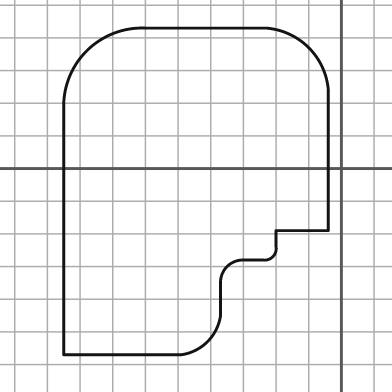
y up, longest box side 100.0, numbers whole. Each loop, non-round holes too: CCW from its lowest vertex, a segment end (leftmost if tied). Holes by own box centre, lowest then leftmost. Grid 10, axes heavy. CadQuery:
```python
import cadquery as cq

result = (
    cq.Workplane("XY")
    .moveTo(-85.0, -57.0)
    .lineTo(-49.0, -57.0)
    .threePointArc((-41.0, -53.0), (-37.0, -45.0))
    .lineTo(-37.0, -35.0)
    .threePointArc((-35.0, -30.0), (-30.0, -28.0))
    .lineTo(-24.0, -28.0)
    .threePointArc((-21.0, -27.0), (-20.0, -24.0))
    .lineTo(-20.0, -19.0)
    .lineTo(-4.0, -19.0)
    .lineTo(-4.0, 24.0)
    .threePointArc((-10.0, 37.0), (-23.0, 43.0))
    .lineTo(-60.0, 43.0)
    .threePointArc((-78.0, 36.0), (-85.0, 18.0))
    .close()
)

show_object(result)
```